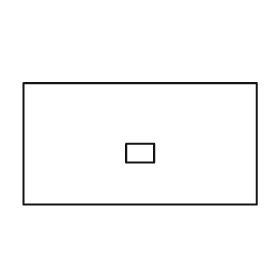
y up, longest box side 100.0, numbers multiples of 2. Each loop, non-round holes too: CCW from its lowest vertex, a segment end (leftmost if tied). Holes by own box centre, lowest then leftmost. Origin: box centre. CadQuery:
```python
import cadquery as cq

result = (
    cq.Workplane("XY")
    .moveTo(-50.0, -26.0)
    .lineTo(50.0, -26.0)
    .lineTo(50.0, 26.0)
    .lineTo(-50.0, 26.0)
    .close()
    .moveTo(-6.0, -8.0)
    .lineTo(6.0, -8.0)
    .lineTo(6.0, 0.0)
    .lineTo(-6.0, 0.0)
    .close()
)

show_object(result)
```